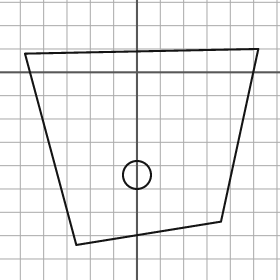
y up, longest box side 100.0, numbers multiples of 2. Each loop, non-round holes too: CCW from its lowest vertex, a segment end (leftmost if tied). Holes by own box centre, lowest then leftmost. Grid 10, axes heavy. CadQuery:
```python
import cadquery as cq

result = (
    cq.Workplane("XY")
    .moveTo(-26.0, -74.0)
    .lineTo(36.0, -64.0)
    .lineTo(52.0, 10.0)
    .lineTo(-48.0, 8.0)
    .close()
    .moveTo(0.0, -44.0)
    .circle(6.0)
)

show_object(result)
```